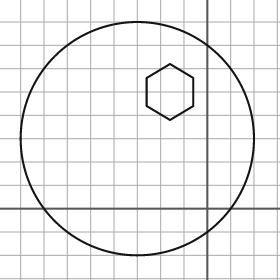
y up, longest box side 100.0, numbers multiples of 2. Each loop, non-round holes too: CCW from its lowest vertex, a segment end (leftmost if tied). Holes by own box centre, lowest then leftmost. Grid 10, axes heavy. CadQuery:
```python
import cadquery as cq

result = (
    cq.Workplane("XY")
    .moveTo(-30.0, 30.0)
    .circle(50.0)
    .moveTo(-16.0, 38.0)
    .lineTo(-6.0, 44.0)
    .lineTo(-6.0, 56.0)
    .lineTo(-16.0, 62.0)
    .lineTo(-26.0, 56.0)
    .lineTo(-26.0, 44.0)
    .close()
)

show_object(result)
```